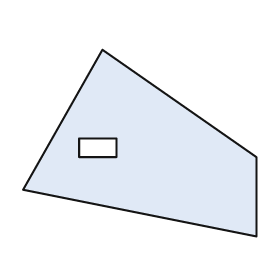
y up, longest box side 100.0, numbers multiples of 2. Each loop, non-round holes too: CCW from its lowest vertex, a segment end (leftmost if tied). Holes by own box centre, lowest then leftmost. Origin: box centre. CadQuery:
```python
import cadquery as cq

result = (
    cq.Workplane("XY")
    .moveTo(50.0, -40.0)
    .lineTo(50.0, -6.0)
    .lineTo(-16.0, 40.0)
    .lineTo(-50.0, -20.0)
    .close()
    .moveTo(-26.0, -6.0)
    .lineTo(-10.0, -6.0)
    .lineTo(-10.0, 2.0)
    .lineTo(-26.0, 2.0)
    .close()
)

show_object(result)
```